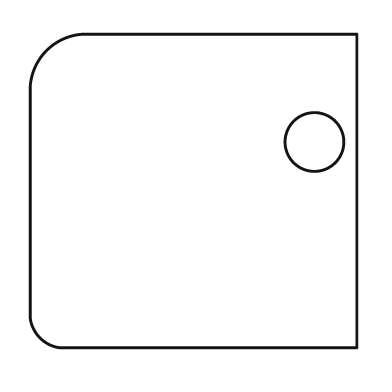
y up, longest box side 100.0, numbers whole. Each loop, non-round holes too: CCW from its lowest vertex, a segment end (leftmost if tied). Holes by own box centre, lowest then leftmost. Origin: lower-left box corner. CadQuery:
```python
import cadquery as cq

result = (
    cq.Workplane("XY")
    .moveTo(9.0, 0.0)
    .lineTo(100.0, 0.0)
    .lineTo(100.0, 96.0)
    .lineTo(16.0, 96.0)
    .threePointArc((5.0, 91.0), (0.0, 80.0))
    .lineTo(0.0, 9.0)
    .threePointArc((3.0, 3.0), (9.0, 0.0))
    .close()
    .moveTo(87.0, 63.0)
    .circle(9.0)
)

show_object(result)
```